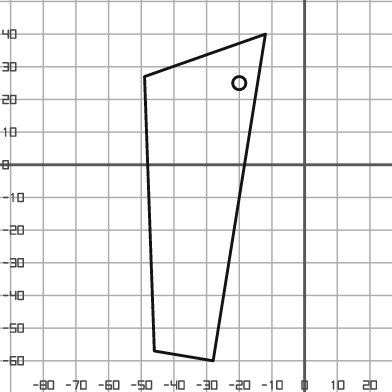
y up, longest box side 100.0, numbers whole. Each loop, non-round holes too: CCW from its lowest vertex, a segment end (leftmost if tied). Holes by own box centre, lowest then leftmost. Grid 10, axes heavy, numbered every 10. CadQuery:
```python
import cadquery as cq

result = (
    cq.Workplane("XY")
    .moveTo(-28.0, -60.0)
    .lineTo(-12.0, 40.0)
    .lineTo(-49.0, 27.0)
    .lineTo(-46.0, -57.0)
    .close()
    .moveTo(-20.0, 25.0)
    .circle(2.0)
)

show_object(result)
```